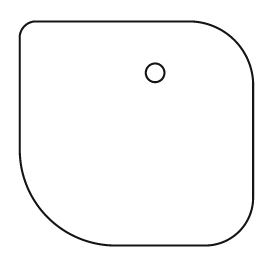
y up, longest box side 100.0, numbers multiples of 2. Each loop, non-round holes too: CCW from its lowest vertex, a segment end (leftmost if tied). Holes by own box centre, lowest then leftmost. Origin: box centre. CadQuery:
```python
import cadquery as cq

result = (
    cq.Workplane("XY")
    .moveTo(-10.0, -48.0)
    .lineTo(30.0, -48.0)
    .threePointArc((44.0, -42.0), (50.0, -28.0))
    .lineTo(50.0, 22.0)
    .threePointArc((42.0, 40.0), (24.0, 48.0))
    .lineTo(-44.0, 48.0)
    .threePointArc((-48.0, 46.0), (-50.0, 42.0))
    .lineTo(-50.0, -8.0)
    .threePointArc((-38.0, -36.0), (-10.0, -48.0))
    .close()
    .moveTo(8.0, 26.0)
    .circle(4.0)
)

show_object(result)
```